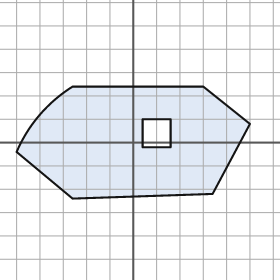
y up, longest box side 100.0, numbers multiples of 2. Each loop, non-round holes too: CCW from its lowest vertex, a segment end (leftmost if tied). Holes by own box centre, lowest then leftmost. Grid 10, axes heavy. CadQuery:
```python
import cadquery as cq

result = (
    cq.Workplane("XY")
    .moveTo(-26.0, -24.0)
    .lineTo(34.0, -22.0)
    .lineTo(50.0, 8.0)
    .lineTo(30.0, 24.0)
    .lineTo(-26.0, 24.0)
    .threePointArc((-40.0, 12.0), (-50.0, -4.0))
    .close()
    .moveTo(4.0, -2.0)
    .lineTo(16.0, -2.0)
    .lineTo(16.0, 10.0)
    .lineTo(4.0, 10.0)
    .close()
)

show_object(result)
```